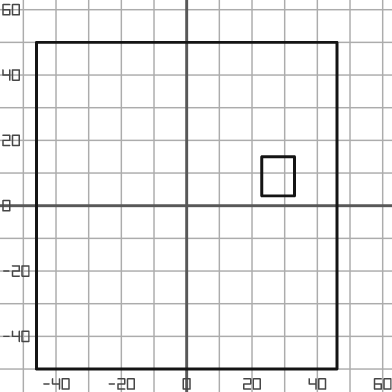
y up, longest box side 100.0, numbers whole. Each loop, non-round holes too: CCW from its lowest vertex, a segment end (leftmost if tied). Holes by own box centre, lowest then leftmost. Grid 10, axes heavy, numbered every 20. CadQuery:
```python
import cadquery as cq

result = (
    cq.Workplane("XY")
    .moveTo(-46.0, -50.0)
    .lineTo(46.0, -50.0)
    .lineTo(46.0, 50.0)
    .lineTo(-46.0, 50.0)
    .close()
    .moveTo(23.0, 3.0)
    .lineTo(33.0, 3.0)
    .lineTo(33.0, 15.0)
    .lineTo(23.0, 15.0)
    .close()
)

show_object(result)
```